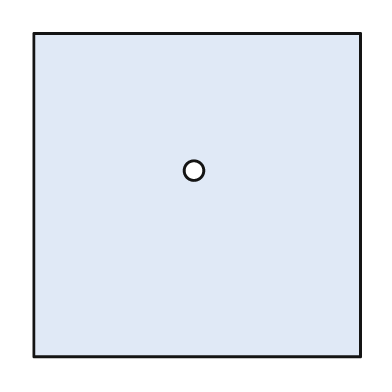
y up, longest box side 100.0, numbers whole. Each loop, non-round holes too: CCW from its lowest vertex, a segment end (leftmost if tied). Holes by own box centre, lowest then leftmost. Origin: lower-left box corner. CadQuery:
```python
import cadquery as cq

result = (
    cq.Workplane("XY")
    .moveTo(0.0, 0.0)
    .lineTo(100.0, 0.0)
    .lineTo(100.0, 99.0)
    .lineTo(0.0, 99.0)
    .close()
    .moveTo(49.0, 57.0)
    .circle(3.0)
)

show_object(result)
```